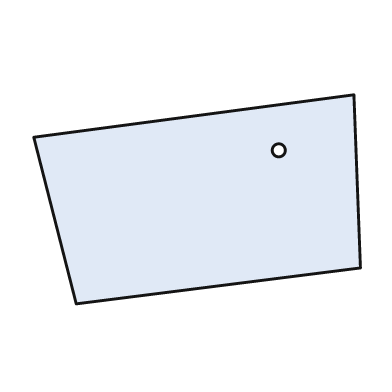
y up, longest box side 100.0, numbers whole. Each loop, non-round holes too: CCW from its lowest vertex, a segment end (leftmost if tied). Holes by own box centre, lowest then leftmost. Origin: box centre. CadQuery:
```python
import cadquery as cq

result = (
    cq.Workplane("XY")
    .moveTo(-37.0, -32.0)
    .lineTo(50.0, -21.0)
    .lineTo(48.0, 32.0)
    .lineTo(-50.0, 19.0)
    .close()
    .moveTo(25.0, 15.0)
    .circle(2.0)
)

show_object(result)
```